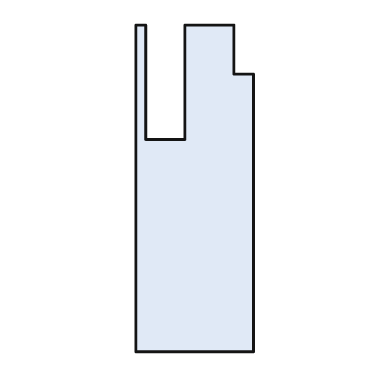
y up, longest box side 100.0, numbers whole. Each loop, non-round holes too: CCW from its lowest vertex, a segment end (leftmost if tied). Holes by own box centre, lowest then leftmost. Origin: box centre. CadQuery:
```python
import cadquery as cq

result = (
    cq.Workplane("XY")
    .moveTo(-18.0, -50.0)
    .lineTo(18.0, -50.0)
    .lineTo(18.0, 35.0)
    .lineTo(12.0, 35.0)
    .lineTo(12.0, 50.0)
    .lineTo(-3.0, 50.0)
    .lineTo(-3.0, 15.0)
    .lineTo(-15.0, 15.0)
    .lineTo(-15.0, 50.0)
    .lineTo(-18.0, 50.0)
    .close()
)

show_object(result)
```